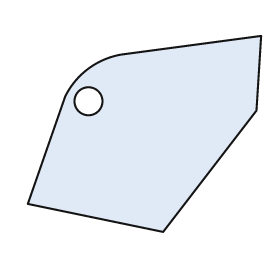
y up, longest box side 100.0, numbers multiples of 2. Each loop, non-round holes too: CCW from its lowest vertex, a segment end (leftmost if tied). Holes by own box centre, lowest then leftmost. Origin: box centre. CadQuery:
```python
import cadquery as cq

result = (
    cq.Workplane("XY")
    .moveTo(8.0, -42.0)
    .lineTo(48.0, 10.0)
    .lineTo(50.0, 42.0)
    .lineTo(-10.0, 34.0)
    .threePointArc((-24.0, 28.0), (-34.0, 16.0))
    .lineTo(-50.0, -30.0)
    .close()
    .moveTo(-24.0, 14.0)
    .circle(6.0)
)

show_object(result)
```